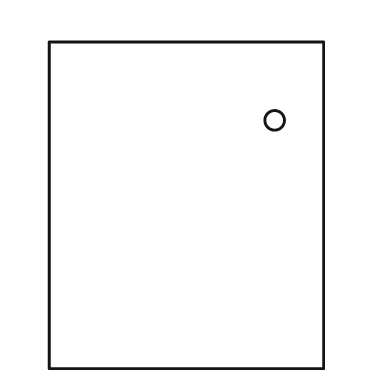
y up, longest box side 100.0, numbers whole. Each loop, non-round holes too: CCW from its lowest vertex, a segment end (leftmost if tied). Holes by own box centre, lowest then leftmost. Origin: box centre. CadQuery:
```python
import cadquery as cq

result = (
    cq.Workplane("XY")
    .moveTo(-42.0, -50.0)
    .lineTo(42.0, -50.0)
    .lineTo(42.0, 50.0)
    .lineTo(-42.0, 50.0)
    .close()
    .moveTo(27.0, 26.0)
    .circle(3.0)
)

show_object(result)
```